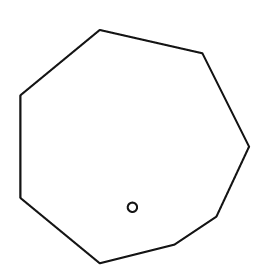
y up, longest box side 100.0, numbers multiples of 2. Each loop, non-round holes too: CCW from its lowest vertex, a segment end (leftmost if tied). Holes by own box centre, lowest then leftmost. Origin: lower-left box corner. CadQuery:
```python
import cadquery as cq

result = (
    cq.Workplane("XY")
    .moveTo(34.0, 0.0)
    .lineTo(66.0, 8.0)
    .lineTo(84.0, 20.0)
    .lineTo(98.0, 50.0)
    .lineTo(78.0, 90.0)
    .lineTo(34.0, 100.0)
    .lineTo(0.0, 72.0)
    .lineTo(0.0, 28.0)
    .close()
    .moveTo(48.0, 24.0)
    .circle(2.0)
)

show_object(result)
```